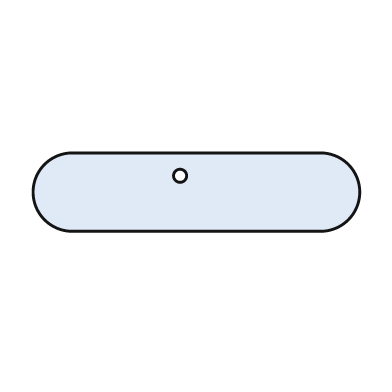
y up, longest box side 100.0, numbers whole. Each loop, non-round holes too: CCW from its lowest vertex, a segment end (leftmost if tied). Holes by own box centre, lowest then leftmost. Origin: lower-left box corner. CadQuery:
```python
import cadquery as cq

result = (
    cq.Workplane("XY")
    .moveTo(12.0, 0.0)
    .lineTo(88.0, 0.0)
    .threePointArc((100.0, 12.0), (88.0, 24.0))
    .lineTo(12.0, 24.0)
    .threePointArc((0.0, 12.0), (12.0, 0.0))
    .close()
    .moveTo(45.0, 17.0)
    .circle(2.0)
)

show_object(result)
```